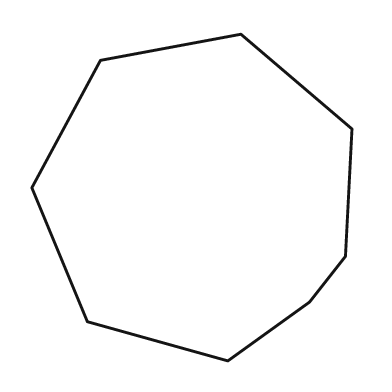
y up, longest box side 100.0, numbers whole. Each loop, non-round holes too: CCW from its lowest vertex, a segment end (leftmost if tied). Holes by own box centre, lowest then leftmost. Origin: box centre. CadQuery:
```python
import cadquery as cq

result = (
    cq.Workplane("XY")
    .moveTo(11.0, -50.0)
    .lineTo(36.0, -32.0)
    .lineTo(47.0, -18.0)
    .lineTo(49.0, 21.0)
    .lineTo(15.0, 50.0)
    .lineTo(-28.0, 42.0)
    .lineTo(-49.0, 3.0)
    .lineTo(-32.0, -38.0)
    .close()
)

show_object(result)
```